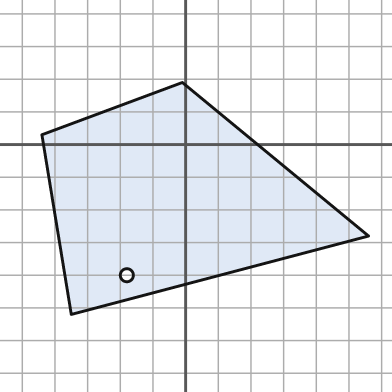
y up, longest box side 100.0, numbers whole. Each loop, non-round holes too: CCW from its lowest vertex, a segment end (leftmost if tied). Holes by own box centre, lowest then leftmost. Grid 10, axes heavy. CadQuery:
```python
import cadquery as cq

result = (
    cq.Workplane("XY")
    .moveTo(-35.0, -52.0)
    .lineTo(56.0, -28.0)
    .lineTo(-1.0, 19.0)
    .lineTo(-44.0, 3.0)
    .close()
    .moveTo(-18.0, -40.0)
    .circle(2.0)
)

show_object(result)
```